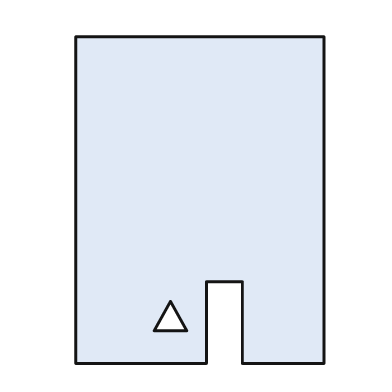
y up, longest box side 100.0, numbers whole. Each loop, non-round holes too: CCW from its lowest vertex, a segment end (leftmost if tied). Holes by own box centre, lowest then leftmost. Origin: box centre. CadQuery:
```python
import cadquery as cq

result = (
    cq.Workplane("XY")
    .moveTo(-38.0, -50.0)
    .lineTo(2.0, -50.0)
    .lineTo(2.0, -25.0)
    .lineTo(13.0, -25.0)
    .lineTo(13.0, -50.0)
    .lineTo(38.0, -50.0)
    .lineTo(38.0, 50.0)
    .lineTo(-38.0, 50.0)
    .close()
    .moveTo(-14.0, -40.0)
    .lineTo(-4.0, -40.0)
    .lineTo(-9.0, -31.0)
    .close()
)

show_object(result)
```